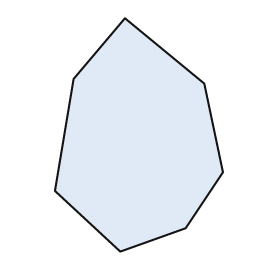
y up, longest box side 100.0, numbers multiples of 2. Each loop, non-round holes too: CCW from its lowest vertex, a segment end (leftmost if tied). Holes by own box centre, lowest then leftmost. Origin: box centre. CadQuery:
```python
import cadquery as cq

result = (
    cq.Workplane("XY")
    .moveTo(-8.0, -50.0)
    .lineTo(20.0, -40.0)
    .lineTo(36.0, -16.0)
    .lineTo(28.0, 22.0)
    .lineTo(-6.0, 50.0)
    .lineTo(-28.0, 24.0)
    .lineTo(-36.0, -24.0)
    .close()
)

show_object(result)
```